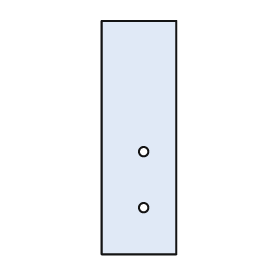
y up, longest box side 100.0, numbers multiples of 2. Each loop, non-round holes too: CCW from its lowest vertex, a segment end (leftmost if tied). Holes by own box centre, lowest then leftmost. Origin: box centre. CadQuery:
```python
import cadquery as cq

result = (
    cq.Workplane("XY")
    .moveTo(-16.0, -50.0)
    .lineTo(16.0, -50.0)
    .lineTo(16.0, 50.0)
    .lineTo(-16.0, 50.0)
    .close()
    .moveTo(2.0, -30.0)
    .circle(2.0)
    .moveTo(2.0, -6.0)
    .circle(2.0)
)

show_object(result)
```